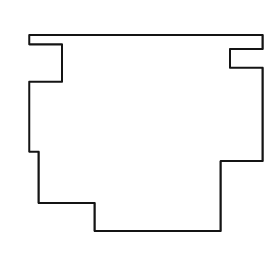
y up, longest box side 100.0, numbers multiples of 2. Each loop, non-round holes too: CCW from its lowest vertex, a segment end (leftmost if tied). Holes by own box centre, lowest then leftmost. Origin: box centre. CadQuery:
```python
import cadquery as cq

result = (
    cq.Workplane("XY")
    .moveTo(-22.0, -42.0)
    .lineTo(32.0, -42.0)
    .lineTo(32.0, -12.0)
    .lineTo(50.0, -12.0)
    .lineTo(50.0, 28.0)
    .lineTo(36.0, 28.0)
    .lineTo(36.0, 36.0)
    .lineTo(50.0, 36.0)
    .lineTo(50.0, 42.0)
    .lineTo(-50.0, 42.0)
    .lineTo(-50.0, 38.0)
    .lineTo(-36.0, 38.0)
    .lineTo(-36.0, 22.0)
    .lineTo(-50.0, 22.0)
    .lineTo(-50.0, -8.0)
    .lineTo(-46.0, -8.0)
    .lineTo(-46.0, -30.0)
    .lineTo(-22.0, -30.0)
    .close()
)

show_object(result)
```